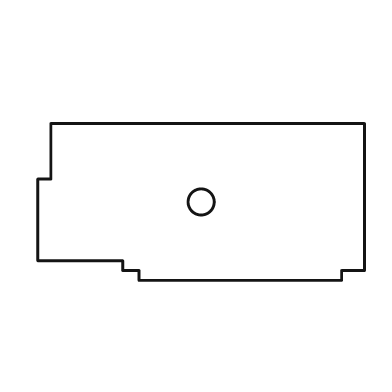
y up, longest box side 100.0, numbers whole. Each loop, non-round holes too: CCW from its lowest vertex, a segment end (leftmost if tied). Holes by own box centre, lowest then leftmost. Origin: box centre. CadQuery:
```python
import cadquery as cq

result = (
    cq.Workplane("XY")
    .moveTo(-19.0, -24.0)
    .lineTo(43.0, -24.0)
    .lineTo(43.0, -21.0)
    .lineTo(50.0, -21.0)
    .lineTo(50.0, 24.0)
    .lineTo(-46.0, 24.0)
    .lineTo(-46.0, 7.0)
    .lineTo(-50.0, 7.0)
    .lineTo(-50.0, -18.0)
    .lineTo(-24.0, -18.0)
    .lineTo(-24.0, -21.0)
    .lineTo(-19.0, -21.0)
    .close()
    .moveTo(0.0, 0.0)
    .circle(4.0)
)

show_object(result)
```